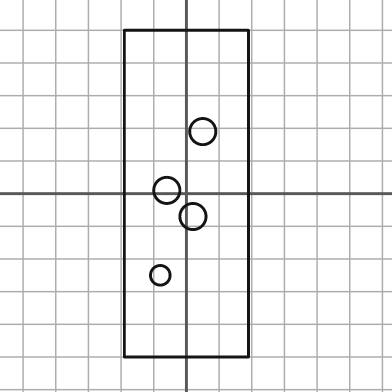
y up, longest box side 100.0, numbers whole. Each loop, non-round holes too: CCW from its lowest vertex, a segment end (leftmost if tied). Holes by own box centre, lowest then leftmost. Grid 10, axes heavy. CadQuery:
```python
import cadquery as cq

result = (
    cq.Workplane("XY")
    .moveTo(-19.0, -50.0)
    .lineTo(19.0, -50.0)
    .lineTo(19.0, 50.0)
    .lineTo(-19.0, 50.0)
    .close()
    .moveTo(-8.0, -25.0)
    .circle(3.0)
    .moveTo(2.0, -7.0)
    .circle(4.0)
    .moveTo(-6.0, 1.0)
    .circle(4.0)
    .moveTo(5.0, 19.0)
    .circle(4.0)
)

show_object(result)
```